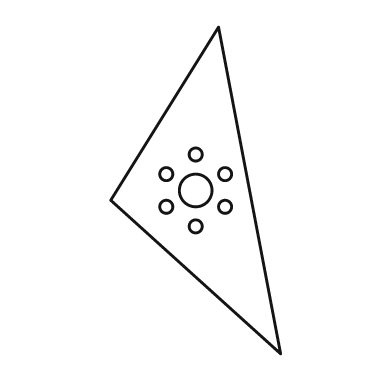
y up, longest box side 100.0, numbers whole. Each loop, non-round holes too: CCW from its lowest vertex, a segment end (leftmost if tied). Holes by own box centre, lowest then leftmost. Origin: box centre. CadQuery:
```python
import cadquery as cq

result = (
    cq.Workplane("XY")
    .moveTo(26.0, -50.0)
    .lineTo(7.0, 50.0)
    .lineTo(-26.0, -3.0)
    .close()
    .moveTo(0.0, -11.0)
    .circle(2.0)
    .moveTo(-9.0, -5.0)
    .circle(2.0)
    .moveTo(9.0, -5.0)
    .circle(2.0)
    .moveTo(0.0, 0.0)
    .circle(5.0)
    .moveTo(-9.0, 5.0)
    .circle(2.0)
    .moveTo(9.0, 5.0)
    .circle(2.0)
    .moveTo(0.0, 11.0)
    .circle(2.0)
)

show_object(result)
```